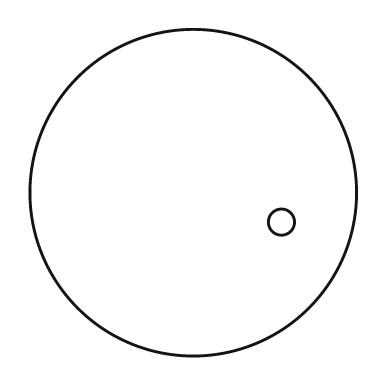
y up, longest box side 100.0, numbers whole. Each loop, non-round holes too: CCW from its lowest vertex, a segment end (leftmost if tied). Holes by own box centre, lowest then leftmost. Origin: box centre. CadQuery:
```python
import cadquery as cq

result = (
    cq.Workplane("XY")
    .moveTo(0.0, 0.0)
    .circle(50.0)
    .moveTo(27.0, -9.0)
    .circle(4.0)
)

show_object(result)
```